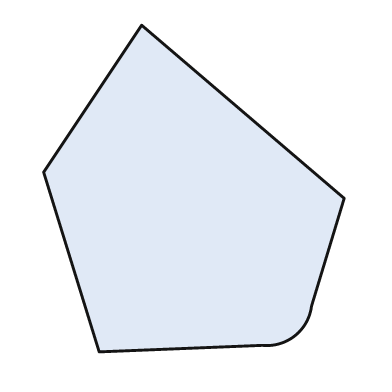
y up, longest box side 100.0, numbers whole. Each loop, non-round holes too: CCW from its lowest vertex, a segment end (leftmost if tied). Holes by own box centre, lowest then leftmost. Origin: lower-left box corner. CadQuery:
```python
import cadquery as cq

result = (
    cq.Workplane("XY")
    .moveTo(17.0, 0.0)
    .lineTo(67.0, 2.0)
    .threePointArc((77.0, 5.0), (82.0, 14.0))
    .lineTo(92.0, 47.0)
    .lineTo(30.0, 100.0)
    .lineTo(0.0, 55.0)
    .close()
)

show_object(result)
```